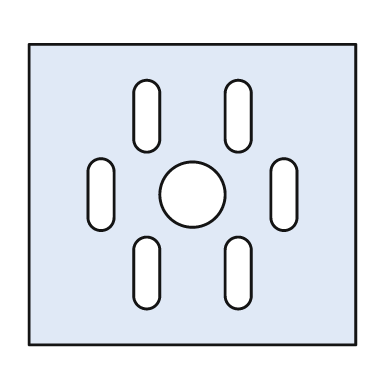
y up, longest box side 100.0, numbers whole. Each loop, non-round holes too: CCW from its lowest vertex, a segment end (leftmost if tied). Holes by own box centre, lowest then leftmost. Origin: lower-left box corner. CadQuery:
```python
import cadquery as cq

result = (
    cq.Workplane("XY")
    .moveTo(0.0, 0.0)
    .lineTo(100.0, 0.0)
    .lineTo(100.0, 92.0)
    .lineTo(0.0, 92.0)
    .close()
    .moveTo(32.0, 15.0)
    .threePointArc((36.0, 11.0), (40.0, 15.0))
    .lineTo(40.0, 29.0)
    .threePointArc((36.0, 33.0), (32.0, 29.0))
    .close()
    .moveTo(60.0, 15.0)
    .threePointArc((64.0, 11.0), (68.0, 15.0))
    .lineTo(68.0, 29.0)
    .threePointArc((64.0, 33.0), (60.0, 29.0))
    .close()
    .moveTo(18.0, 39.0)
    .threePointArc((22.0, 35.0), (26.0, 39.0))
    .lineTo(26.0, 53.0)
    .threePointArc((22.0, 57.0), (18.0, 53.0))
    .close()
    .moveTo(50.0, 46.0)
    .circle(10.0)
    .moveTo(74.0, 39.0)
    .threePointArc((78.0, 35.0), (82.0, 39.0))
    .lineTo(82.0, 53.0)
    .threePointArc((78.0, 57.0), (74.0, 53.0))
    .close()
    .moveTo(32.0, 63.0)
    .threePointArc((36.0, 59.0), (40.0, 63.0))
    .lineTo(40.0, 77.0)
    .threePointArc((36.0, 81.0), (32.0, 77.0))
    .close()
    .moveTo(60.0, 63.0)
    .threePointArc((64.0, 59.0), (68.0, 63.0))
    .lineTo(68.0, 77.0)
    .threePointArc((64.0, 81.0), (60.0, 77.0))
    .close()
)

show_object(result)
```